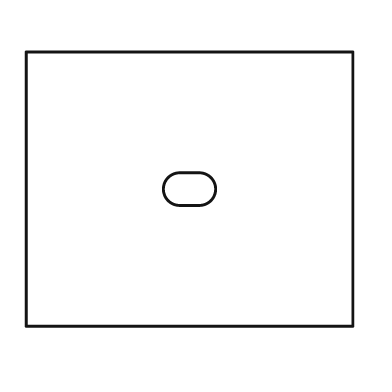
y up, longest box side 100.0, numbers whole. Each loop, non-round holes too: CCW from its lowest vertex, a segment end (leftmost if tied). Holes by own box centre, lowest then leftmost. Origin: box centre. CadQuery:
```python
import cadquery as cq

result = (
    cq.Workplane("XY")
    .moveTo(-50.0, -42.0)
    .lineTo(50.0, -42.0)
    .lineTo(50.0, 42.0)
    .lineTo(-50.0, 42.0)
    .close()
    .moveTo(-3.0, -5.0)
    .lineTo(3.0, -5.0)
    .threePointArc((8.0, 0.0), (3.0, 5.0))
    .lineTo(-3.0, 5.0)
    .threePointArc((-8.0, 0.0), (-3.0, -5.0))
    .close()
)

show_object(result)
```